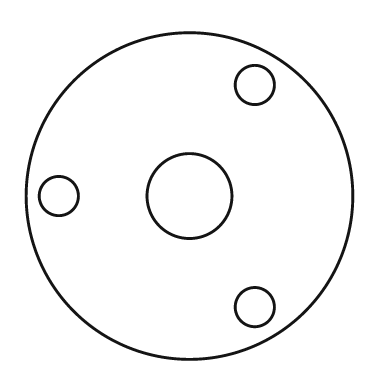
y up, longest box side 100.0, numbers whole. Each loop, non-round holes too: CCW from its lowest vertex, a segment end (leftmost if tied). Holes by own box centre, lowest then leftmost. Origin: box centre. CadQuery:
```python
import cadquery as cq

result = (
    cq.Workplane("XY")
    .moveTo(0.0, 0.0)
    .circle(50.0)
    .moveTo(20.0, -34.0)
    .circle(6.0)
    .moveTo(-40.0, 0.0)
    .circle(6.0)
    .moveTo(0.0, 0.0)
    .circle(13.0)
    .moveTo(20.0, 34.0)
    .circle(6.0)
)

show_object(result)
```